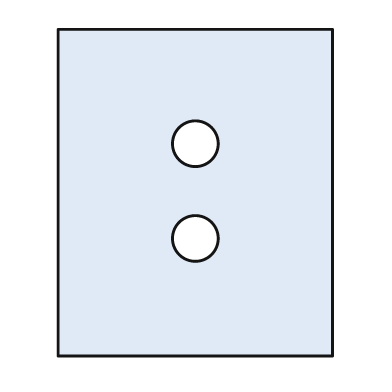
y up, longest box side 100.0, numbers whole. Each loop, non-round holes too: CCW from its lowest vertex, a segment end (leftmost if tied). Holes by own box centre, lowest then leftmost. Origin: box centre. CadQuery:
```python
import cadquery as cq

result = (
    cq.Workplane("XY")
    .moveTo(-42.0, -50.0)
    .lineTo(42.0, -50.0)
    .lineTo(42.0, 50.0)
    .lineTo(-42.0, 50.0)
    .close()
    .moveTo(0.0, -14.0)
    .circle(7.0)
    .moveTo(0.0, 15.0)
    .circle(7.0)
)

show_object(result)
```